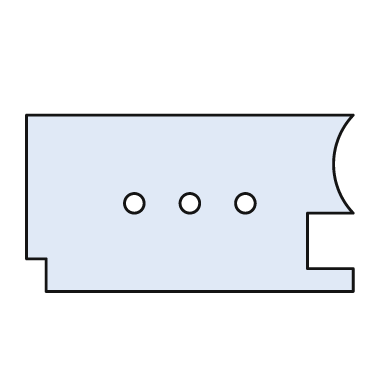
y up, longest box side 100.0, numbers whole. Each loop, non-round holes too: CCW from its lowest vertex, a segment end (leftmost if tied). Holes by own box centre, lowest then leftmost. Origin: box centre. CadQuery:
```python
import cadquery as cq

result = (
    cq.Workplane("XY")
    .moveTo(-44.0, -27.0)
    .lineTo(50.0, -27.0)
    .lineTo(50.0, -20.0)
    .lineTo(36.0, -20.0)
    .lineTo(36.0, -3.0)
    .lineTo(50.0, -3.0)
    .threePointArc((44.0, 12.0), (50.0, 27.0))
    .lineTo(-50.0, 27.0)
    .lineTo(-50.0, -17.0)
    .lineTo(-44.0, -17.0)
    .close()
    .moveTo(-17.0, 0.0)
    .circle(3.0)
    .moveTo(0.0, 0.0)
    .circle(3.0)
    .moveTo(17.0, 0.0)
    .circle(3.0)
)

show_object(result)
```